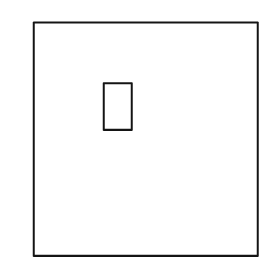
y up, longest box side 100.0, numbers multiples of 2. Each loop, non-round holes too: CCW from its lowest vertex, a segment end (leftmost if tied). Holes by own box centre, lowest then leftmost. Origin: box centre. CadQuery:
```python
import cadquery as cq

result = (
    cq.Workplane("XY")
    .moveTo(-48.0, -50.0)
    .lineTo(48.0, -50.0)
    .lineTo(48.0, 50.0)
    .lineTo(-48.0, 50.0)
    .close()
    .moveTo(-18.0, 4.0)
    .lineTo(-6.0, 4.0)
    .lineTo(-6.0, 24.0)
    .lineTo(-18.0, 24.0)
    .close()
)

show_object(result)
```